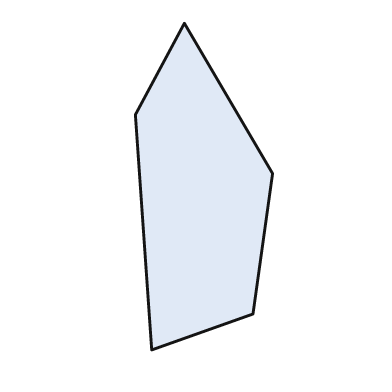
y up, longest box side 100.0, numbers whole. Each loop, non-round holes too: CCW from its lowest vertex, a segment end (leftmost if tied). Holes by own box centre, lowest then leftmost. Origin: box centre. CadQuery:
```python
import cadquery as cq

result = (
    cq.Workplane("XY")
    .moveTo(-16.0, -50.0)
    .lineTo(15.0, -39.0)
    .lineTo(21.0, 4.0)
    .lineTo(-6.0, 50.0)
    .lineTo(-21.0, 22.0)
    .close()
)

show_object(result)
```